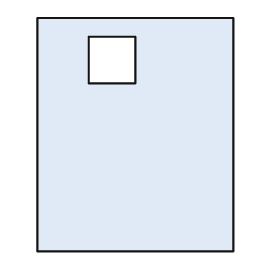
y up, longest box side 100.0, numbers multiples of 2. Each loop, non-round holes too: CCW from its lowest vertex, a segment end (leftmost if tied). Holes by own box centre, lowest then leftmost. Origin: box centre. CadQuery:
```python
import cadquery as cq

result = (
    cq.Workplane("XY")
    .moveTo(-42.0, -50.0)
    .lineTo(42.0, -50.0)
    .lineTo(42.0, 50.0)
    .lineTo(-42.0, 50.0)
    .close()
    .moveTo(-20.0, 22.0)
    .lineTo(0.0, 22.0)
    .lineTo(0.0, 42.0)
    .lineTo(-20.0, 42.0)
    .close()
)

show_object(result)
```